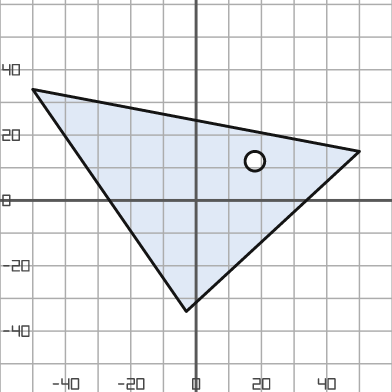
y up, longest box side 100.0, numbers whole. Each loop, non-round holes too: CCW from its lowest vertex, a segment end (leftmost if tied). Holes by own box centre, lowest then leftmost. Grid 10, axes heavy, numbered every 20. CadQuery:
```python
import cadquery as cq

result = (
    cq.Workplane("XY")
    .moveTo(-3.0, -34.0)
    .lineTo(50.0, 15.0)
    .lineTo(-50.0, 34.0)
    .close()
    .moveTo(18.0, 12.0)
    .circle(3.0)
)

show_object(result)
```